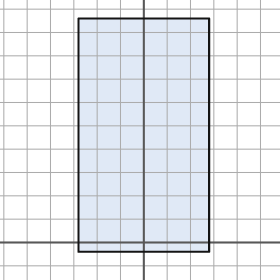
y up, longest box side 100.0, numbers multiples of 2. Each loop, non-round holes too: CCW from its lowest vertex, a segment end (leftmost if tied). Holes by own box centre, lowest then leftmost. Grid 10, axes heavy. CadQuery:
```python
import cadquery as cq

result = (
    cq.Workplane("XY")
    .moveTo(-28.0, -4.0)
    .lineTo(28.0, -4.0)
    .lineTo(28.0, 96.0)
    .lineTo(-28.0, 96.0)
    .close()
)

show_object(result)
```